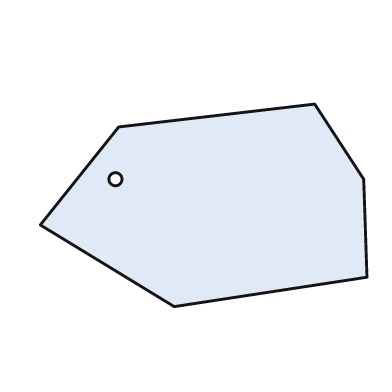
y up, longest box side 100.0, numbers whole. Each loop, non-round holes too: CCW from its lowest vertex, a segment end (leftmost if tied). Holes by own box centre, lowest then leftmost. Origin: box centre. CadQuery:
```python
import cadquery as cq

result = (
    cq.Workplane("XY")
    .moveTo(-9.0, -31.0)
    .lineTo(50.0, -22.0)
    .lineTo(49.0, 8.0)
    .lineTo(34.0, 31.0)
    .lineTo(-26.0, 24.0)
    .lineTo(-50.0, -6.0)
    .close()
    .moveTo(-27.0, 8.0)
    .circle(2.0)
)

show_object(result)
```